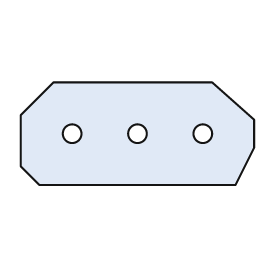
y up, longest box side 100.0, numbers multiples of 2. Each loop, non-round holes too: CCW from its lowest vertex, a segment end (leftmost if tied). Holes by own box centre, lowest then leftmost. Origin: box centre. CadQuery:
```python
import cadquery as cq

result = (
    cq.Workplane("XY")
    .moveTo(-42.0, -22.0)
    .lineTo(42.0, -22.0)
    .lineTo(50.0, -6.0)
    .lineTo(50.0, 6.0)
    .lineTo(32.0, 22.0)
    .lineTo(-36.0, 22.0)
    .lineTo(-50.0, 8.0)
    .lineTo(-50.0, -14.0)
    .close()
    .moveTo(-28.0, 0.0)
    .circle(4.0)
    .moveTo(0.0, 0.0)
    .circle(4.0)
    .moveTo(28.0, 0.0)
    .circle(4.0)
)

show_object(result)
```